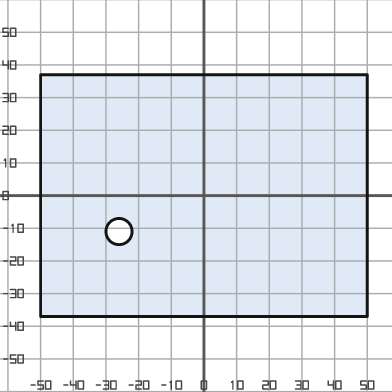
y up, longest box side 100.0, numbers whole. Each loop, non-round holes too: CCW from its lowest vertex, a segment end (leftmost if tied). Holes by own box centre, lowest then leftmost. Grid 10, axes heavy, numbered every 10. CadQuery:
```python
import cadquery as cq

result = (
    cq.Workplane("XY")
    .moveTo(-50.0, -37.0)
    .lineTo(50.0, -37.0)
    .lineTo(50.0, 37.0)
    .lineTo(-50.0, 37.0)
    .close()
    .moveTo(-26.0, -11.0)
    .circle(4.0)
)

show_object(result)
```